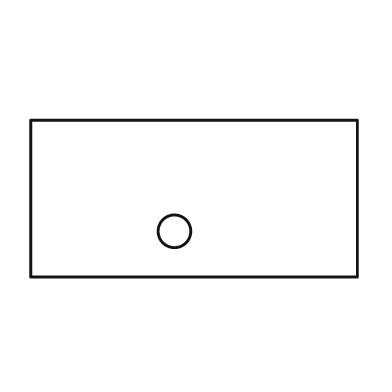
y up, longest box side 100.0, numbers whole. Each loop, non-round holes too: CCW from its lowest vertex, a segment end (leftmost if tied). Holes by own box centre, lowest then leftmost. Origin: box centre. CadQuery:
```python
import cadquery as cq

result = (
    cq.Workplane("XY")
    .moveTo(-50.0, -24.0)
    .lineTo(50.0, -24.0)
    .lineTo(50.0, 24.0)
    .lineTo(-50.0, 24.0)
    .close()
    .moveTo(-6.0, -10.0)
    .circle(5.0)
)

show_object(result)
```